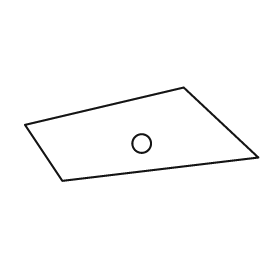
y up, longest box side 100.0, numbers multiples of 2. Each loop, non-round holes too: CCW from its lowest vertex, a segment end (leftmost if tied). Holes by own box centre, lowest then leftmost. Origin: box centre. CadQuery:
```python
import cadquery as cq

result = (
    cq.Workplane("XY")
    .moveTo(-34.0, -20.0)
    .lineTo(50.0, -10.0)
    .lineTo(18.0, 20.0)
    .lineTo(-50.0, 4.0)
    .close()
    .moveTo(0.0, -4.0)
    .circle(4.0)
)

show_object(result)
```